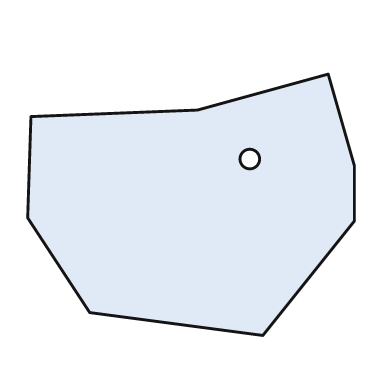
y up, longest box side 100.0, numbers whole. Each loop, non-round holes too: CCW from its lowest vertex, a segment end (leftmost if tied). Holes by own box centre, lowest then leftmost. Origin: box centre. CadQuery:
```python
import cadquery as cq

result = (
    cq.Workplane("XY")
    .moveTo(22.0, -40.0)
    .lineTo(50.0, -5.0)
    .lineTo(50.0, 12.0)
    .lineTo(42.0, 40.0)
    .lineTo(2.0, 29.0)
    .lineTo(-49.0, 27.0)
    .lineTo(-50.0, -4.0)
    .lineTo(-31.0, -33.0)
    .close()
    .moveTo(18.0, 14.0)
    .circle(3.0)
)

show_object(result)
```